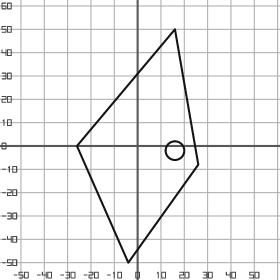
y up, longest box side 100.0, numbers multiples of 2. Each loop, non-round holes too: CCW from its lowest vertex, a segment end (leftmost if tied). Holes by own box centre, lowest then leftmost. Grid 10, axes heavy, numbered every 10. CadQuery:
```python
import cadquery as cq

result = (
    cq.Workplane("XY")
    .moveTo(-4.0, -50.0)
    .lineTo(26.0, -8.0)
    .lineTo(16.0, 50.0)
    .lineTo(-26.0, 0.0)
    .close()
    .moveTo(16.0, -2.0)
    .circle(4.0)
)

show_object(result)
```